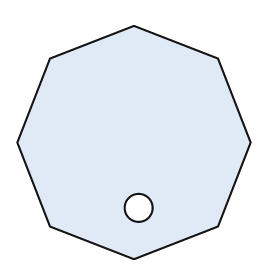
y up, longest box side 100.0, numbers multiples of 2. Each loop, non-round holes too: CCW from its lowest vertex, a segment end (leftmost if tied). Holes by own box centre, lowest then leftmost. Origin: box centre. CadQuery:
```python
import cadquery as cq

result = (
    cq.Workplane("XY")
    .moveTo(0.0, -50.0)
    .lineTo(36.0, -36.0)
    .lineTo(50.0, 0.0)
    .lineTo(36.0, 36.0)
    .lineTo(0.0, 50.0)
    .lineTo(-36.0, 36.0)
    .lineTo(-50.0, 0.0)
    .lineTo(-36.0, -36.0)
    .close()
    .moveTo(2.0, -28.0)
    .circle(6.0)
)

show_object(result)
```